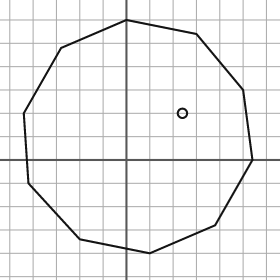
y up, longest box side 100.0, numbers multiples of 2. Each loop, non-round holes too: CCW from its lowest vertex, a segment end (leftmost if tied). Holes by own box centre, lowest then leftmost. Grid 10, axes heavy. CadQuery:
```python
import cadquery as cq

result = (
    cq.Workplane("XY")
    .moveTo(10.0, -40.0)
    .lineTo(38.0, -28.0)
    .lineTo(54.0, 0.0)
    .lineTo(50.0, 30.0)
    .lineTo(30.0, 54.0)
    .lineTo(0.0, 60.0)
    .lineTo(-28.0, 48.0)
    .lineTo(-44.0, 20.0)
    .lineTo(-42.0, -10.0)
    .lineTo(-20.0, -34.0)
    .close()
    .moveTo(24.0, 20.0)
    .circle(2.0)
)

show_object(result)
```